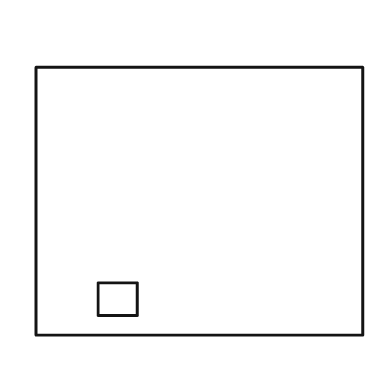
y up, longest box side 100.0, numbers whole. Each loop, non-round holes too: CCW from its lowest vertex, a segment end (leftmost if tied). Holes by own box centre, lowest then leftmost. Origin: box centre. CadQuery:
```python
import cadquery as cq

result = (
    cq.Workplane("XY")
    .moveTo(-50.0, -41.0)
    .lineTo(50.0, -41.0)
    .lineTo(50.0, 41.0)
    .lineTo(-50.0, 41.0)
    .close()
    .moveTo(-31.0, -35.0)
    .lineTo(-19.0, -35.0)
    .lineTo(-19.0, -25.0)
    .lineTo(-31.0, -25.0)
    .close()
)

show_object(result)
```